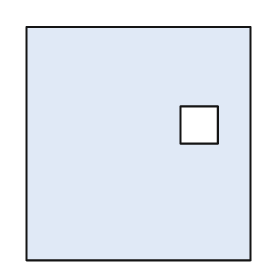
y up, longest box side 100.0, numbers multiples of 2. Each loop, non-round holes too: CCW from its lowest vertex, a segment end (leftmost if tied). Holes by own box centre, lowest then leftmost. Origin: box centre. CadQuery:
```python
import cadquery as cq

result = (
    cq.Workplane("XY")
    .moveTo(-48.0, -50.0)
    .lineTo(48.0, -50.0)
    .lineTo(48.0, 50.0)
    .lineTo(-48.0, 50.0)
    .close()
    .moveTo(18.0, 0.0)
    .lineTo(34.0, 0.0)
    .lineTo(34.0, 16.0)
    .lineTo(18.0, 16.0)
    .close()
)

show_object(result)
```